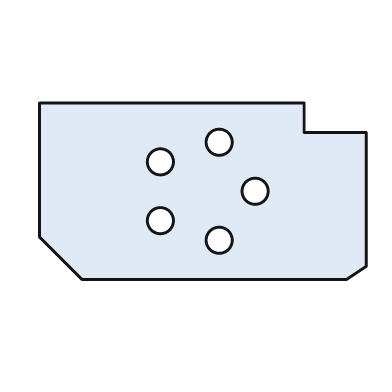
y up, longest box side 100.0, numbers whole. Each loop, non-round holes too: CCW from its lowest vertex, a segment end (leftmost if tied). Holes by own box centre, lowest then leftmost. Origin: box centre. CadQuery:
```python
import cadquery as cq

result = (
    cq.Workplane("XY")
    .moveTo(-37.0, -27.0)
    .lineTo(44.0, -27.0)
    .lineTo(50.0, -23.0)
    .lineTo(50.0, 18.0)
    .lineTo(31.0, 18.0)
    .lineTo(31.0, 27.0)
    .lineTo(-50.0, 27.0)
    .lineTo(-50.0, -14.0)
    .close()
    .moveTo(5.0, -15.0)
    .circle(4.0)
    .moveTo(-13.0, -9.0)
    .circle(4.0)
    .moveTo(16.0, 0.0)
    .circle(4.0)
    .moveTo(-13.0, 9.0)
    .circle(4.0)
    .moveTo(5.0, 15.0)
    .circle(4.0)
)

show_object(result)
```